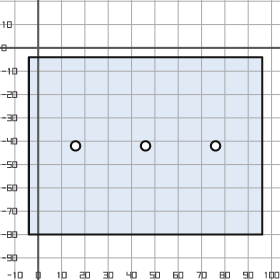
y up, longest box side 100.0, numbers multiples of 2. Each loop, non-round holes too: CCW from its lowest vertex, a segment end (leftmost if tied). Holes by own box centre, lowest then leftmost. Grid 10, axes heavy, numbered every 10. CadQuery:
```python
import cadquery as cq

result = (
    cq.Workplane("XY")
    .moveTo(-4.0, -80.0)
    .lineTo(96.0, -80.0)
    .lineTo(96.0, -4.0)
    .lineTo(-4.0, -4.0)
    .close()
    .moveTo(16.0, -42.0)
    .circle(2.0)
    .moveTo(46.0, -42.0)
    .circle(2.0)
    .moveTo(76.0, -42.0)
    .circle(2.0)
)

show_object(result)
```